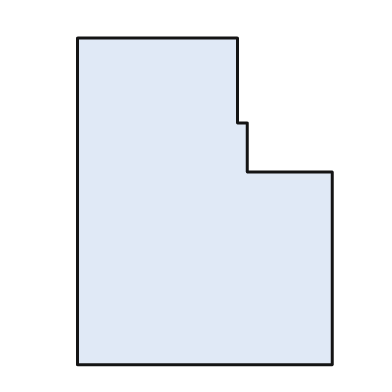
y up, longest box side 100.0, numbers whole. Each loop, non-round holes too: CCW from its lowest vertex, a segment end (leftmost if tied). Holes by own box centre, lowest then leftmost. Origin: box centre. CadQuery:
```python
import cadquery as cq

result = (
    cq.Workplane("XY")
    .moveTo(-39.0, -50.0)
    .lineTo(39.0, -50.0)
    .lineTo(39.0, 9.0)
    .lineTo(13.0, 9.0)
    .lineTo(13.0, 24.0)
    .lineTo(10.0, 24.0)
    .lineTo(10.0, 50.0)
    .lineTo(-39.0, 50.0)
    .close()
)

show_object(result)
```